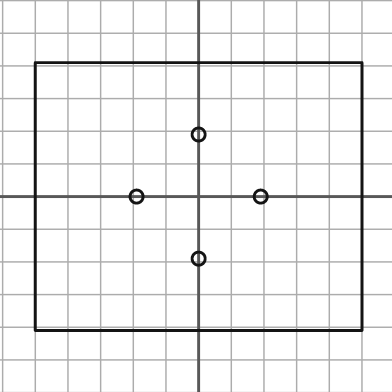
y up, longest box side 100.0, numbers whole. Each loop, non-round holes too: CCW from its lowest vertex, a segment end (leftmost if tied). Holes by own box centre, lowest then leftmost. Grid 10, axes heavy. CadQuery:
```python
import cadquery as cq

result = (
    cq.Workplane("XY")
    .moveTo(-50.0, -41.0)
    .lineTo(50.0, -41.0)
    .lineTo(50.0, 41.0)
    .lineTo(-50.0, 41.0)
    .close()
    .moveTo(0.0, -19.0)
    .circle(2.0)
    .moveTo(-19.0, 0.0)
    .circle(2.0)
    .moveTo(19.0, 0.0)
    .circle(2.0)
    .moveTo(0.0, 19.0)
    .circle(2.0)
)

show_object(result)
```